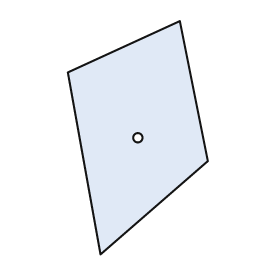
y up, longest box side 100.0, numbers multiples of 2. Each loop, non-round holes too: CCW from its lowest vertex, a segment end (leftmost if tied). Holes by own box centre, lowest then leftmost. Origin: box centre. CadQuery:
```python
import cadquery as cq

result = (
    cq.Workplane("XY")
    .moveTo(-16.0, -50.0)
    .lineTo(30.0, -10.0)
    .lineTo(18.0, 50.0)
    .lineTo(-30.0, 28.0)
    .close()
    .moveTo(0.0, 0.0)
    .circle(2.0)
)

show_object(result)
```